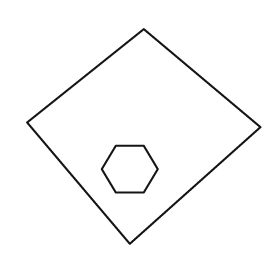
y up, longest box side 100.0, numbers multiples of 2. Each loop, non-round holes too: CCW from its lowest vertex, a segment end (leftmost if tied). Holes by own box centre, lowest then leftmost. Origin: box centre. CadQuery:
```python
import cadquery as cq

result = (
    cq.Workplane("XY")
    .moveTo(-6.0, -46.0)
    .lineTo(50.0, 4.0)
    .lineTo(0.0, 46.0)
    .lineTo(-50.0, 6.0)
    .close()
    .moveTo(-12.0, -24.0)
    .lineTo(0.0, -24.0)
    .lineTo(6.0, -14.0)
    .lineTo(0.0, -4.0)
    .lineTo(-12.0, -4.0)
    .lineTo(-18.0, -14.0)
    .close()
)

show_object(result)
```